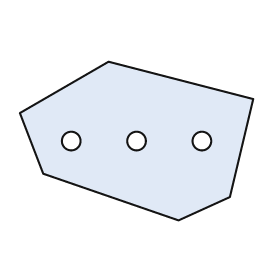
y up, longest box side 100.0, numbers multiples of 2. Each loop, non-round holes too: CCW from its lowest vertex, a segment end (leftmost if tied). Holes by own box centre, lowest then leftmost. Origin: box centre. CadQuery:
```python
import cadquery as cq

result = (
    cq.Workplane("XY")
    .moveTo(18.0, -34.0)
    .lineTo(40.0, -24.0)
    .lineTo(50.0, 18.0)
    .lineTo(-12.0, 34.0)
    .lineTo(-50.0, 12.0)
    .lineTo(-40.0, -14.0)
    .close()
    .moveTo(-28.0, 0.0)
    .circle(4.0)
    .moveTo(0.0, 0.0)
    .circle(4.0)
    .moveTo(28.0, 0.0)
    .circle(4.0)
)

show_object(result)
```